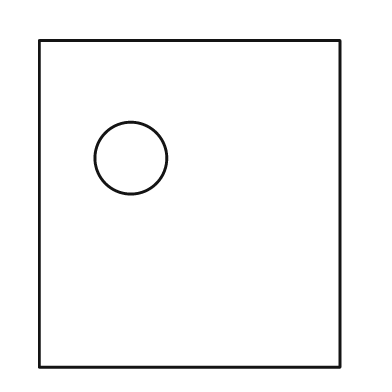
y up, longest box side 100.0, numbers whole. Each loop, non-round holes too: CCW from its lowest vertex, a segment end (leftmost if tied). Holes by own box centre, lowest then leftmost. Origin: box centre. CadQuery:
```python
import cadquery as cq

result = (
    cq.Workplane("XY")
    .moveTo(-46.0, -50.0)
    .lineTo(46.0, -50.0)
    .lineTo(46.0, 50.0)
    .lineTo(-46.0, 50.0)
    .close()
    .moveTo(-18.0, 14.0)
    .circle(11.0)
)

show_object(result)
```